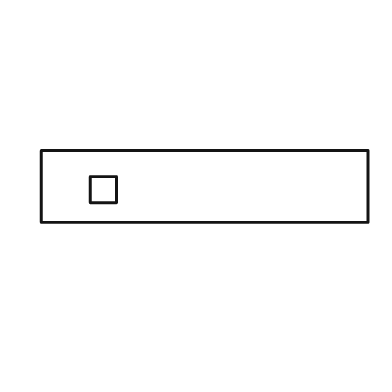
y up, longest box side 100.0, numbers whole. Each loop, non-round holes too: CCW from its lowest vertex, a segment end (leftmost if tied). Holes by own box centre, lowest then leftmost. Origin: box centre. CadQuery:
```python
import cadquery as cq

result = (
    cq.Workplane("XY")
    .moveTo(-50.0, -11.0)
    .lineTo(50.0, -11.0)
    .lineTo(50.0, 11.0)
    .lineTo(-50.0, 11.0)
    .close()
    .moveTo(-35.0, -5.0)
    .lineTo(-27.0, -5.0)
    .lineTo(-27.0, 3.0)
    .lineTo(-35.0, 3.0)
    .close()
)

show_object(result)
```